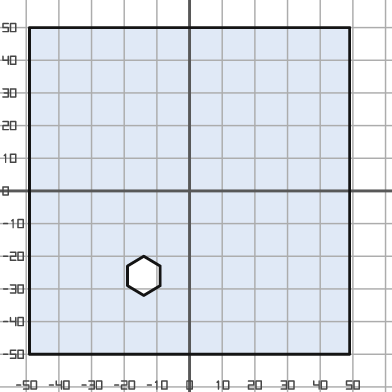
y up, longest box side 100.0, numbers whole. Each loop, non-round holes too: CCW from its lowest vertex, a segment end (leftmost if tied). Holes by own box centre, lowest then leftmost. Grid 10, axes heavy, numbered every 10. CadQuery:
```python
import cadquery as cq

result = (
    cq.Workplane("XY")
    .moveTo(-49.0, -50.0)
    .lineTo(49.0, -50.0)
    .lineTo(49.0, 50.0)
    .lineTo(-49.0, 50.0)
    .close()
    .moveTo(-14.0, -32.0)
    .lineTo(-9.0, -29.0)
    .lineTo(-9.0, -23.0)
    .lineTo(-14.0, -20.0)
    .lineTo(-19.0, -23.0)
    .lineTo(-19.0, -29.0)
    .close()
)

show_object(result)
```